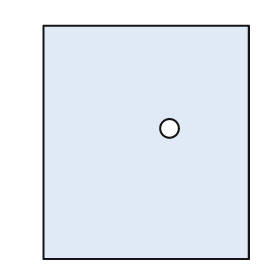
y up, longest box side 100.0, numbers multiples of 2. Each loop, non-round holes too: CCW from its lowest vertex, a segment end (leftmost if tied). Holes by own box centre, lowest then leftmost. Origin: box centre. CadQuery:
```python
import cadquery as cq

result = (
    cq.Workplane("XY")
    .moveTo(-44.0, -50.0)
    .lineTo(44.0, -50.0)
    .lineTo(44.0, 50.0)
    .lineTo(-44.0, 50.0)
    .close()
    .moveTo(10.0, 6.0)
    .circle(4.0)
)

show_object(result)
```